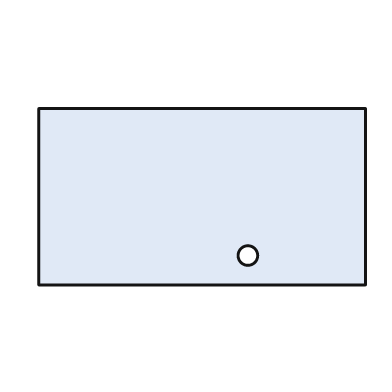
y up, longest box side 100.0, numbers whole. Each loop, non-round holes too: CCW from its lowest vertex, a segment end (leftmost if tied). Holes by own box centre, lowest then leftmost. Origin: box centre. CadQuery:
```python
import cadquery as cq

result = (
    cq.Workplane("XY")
    .moveTo(-50.0, -27.0)
    .lineTo(50.0, -27.0)
    .lineTo(50.0, 27.0)
    .lineTo(-50.0, 27.0)
    .close()
    .moveTo(14.0, -18.0)
    .circle(3.0)
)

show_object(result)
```